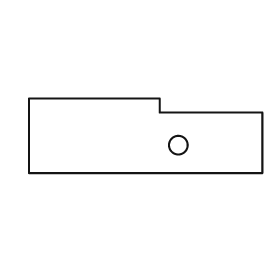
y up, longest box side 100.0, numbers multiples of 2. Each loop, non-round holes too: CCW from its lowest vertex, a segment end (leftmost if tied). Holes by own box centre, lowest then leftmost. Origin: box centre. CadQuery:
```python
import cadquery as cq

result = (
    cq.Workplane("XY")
    .moveTo(-50.0, -16.0)
    .lineTo(50.0, -16.0)
    .lineTo(50.0, 10.0)
    .lineTo(6.0, 10.0)
    .lineTo(6.0, 16.0)
    .lineTo(-50.0, 16.0)
    .close()
    .moveTo(14.0, -4.0)
    .circle(4.0)
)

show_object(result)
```